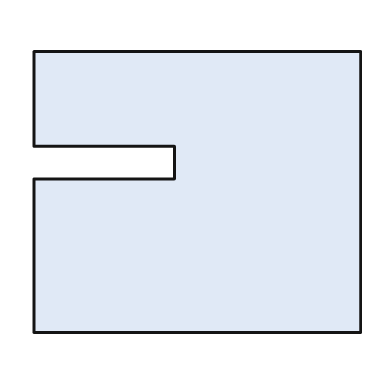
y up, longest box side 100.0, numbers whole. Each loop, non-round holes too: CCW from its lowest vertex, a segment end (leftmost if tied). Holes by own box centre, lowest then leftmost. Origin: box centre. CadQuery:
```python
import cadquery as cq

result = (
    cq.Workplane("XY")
    .moveTo(-50.0, -43.0)
    .lineTo(50.0, -43.0)
    .lineTo(50.0, 43.0)
    .lineTo(-50.0, 43.0)
    .lineTo(-50.0, 14.0)
    .lineTo(-7.0, 14.0)
    .lineTo(-7.0, 4.0)
    .lineTo(-50.0, 4.0)
    .close()
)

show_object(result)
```